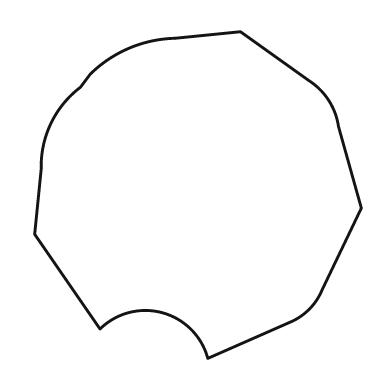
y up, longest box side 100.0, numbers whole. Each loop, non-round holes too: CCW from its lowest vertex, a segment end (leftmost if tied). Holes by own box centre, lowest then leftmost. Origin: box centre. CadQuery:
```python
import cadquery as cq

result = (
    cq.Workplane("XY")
    .moveTo(3.0, -50.0)
    .lineTo(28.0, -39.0)
    .threePointArc((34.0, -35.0), (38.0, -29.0))
    .lineTo(50.0, -4.0)
    .lineTo(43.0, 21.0)
    .threePointArc((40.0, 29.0), (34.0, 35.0))
    .lineTo(13.0, 50.0)
    .lineTo(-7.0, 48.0)
    .threePointArc((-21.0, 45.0), (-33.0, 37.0))
    .lineTo(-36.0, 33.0)
    .threePointArc((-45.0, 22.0), (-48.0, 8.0))
    .lineTo(-50.0, -12.0)
    .lineTo(-30.0, -41.0)
    .threePointArc((-11.0, -36.0), (3.0, -50.0))
    .close()
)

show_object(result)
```